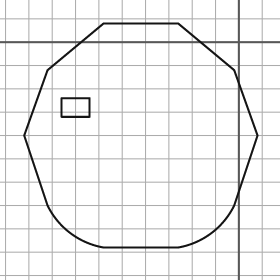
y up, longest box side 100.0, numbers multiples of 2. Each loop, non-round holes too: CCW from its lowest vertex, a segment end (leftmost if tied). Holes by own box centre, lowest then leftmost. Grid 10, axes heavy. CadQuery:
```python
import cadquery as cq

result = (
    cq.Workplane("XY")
    .moveTo(-58.0, -88.0)
    .lineTo(-26.0, -88.0)
    .threePointArc((-12.0, -82.0), (-2.0, -70.0))
    .lineTo(8.0, -40.0)
    .lineTo(-2.0, -12.0)
    .lineTo(-26.0, 8.0)
    .lineTo(-58.0, 8.0)
    .lineTo(-82.0, -12.0)
    .lineTo(-92.0, -40.0)
    .lineTo(-82.0, -70.0)
    .threePointArc((-72.0, -82.0), (-58.0, -88.0))
    .close()
    .moveTo(-76.0, -32.0)
    .lineTo(-64.0, -32.0)
    .lineTo(-64.0, -24.0)
    .lineTo(-76.0, -24.0)
    .close()
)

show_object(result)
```